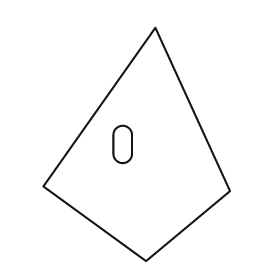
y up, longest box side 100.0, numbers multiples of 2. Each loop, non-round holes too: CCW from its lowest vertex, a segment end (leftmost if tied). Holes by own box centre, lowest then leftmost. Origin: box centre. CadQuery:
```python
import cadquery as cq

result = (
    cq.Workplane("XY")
    .moveTo(4.0, -50.0)
    .lineTo(40.0, -20.0)
    .lineTo(8.0, 50.0)
    .lineTo(-40.0, -18.0)
    .close()
    .moveTo(-10.0, -4.0)
    .threePointArc((-6.0, -8.0), (-2.0, -4.0))
    .lineTo(-2.0, 4.0)
    .threePointArc((-6.0, 8.0), (-10.0, 4.0))
    .close()
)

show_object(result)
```